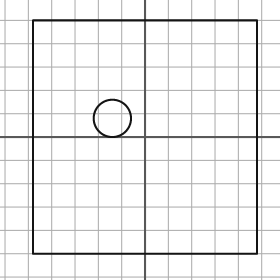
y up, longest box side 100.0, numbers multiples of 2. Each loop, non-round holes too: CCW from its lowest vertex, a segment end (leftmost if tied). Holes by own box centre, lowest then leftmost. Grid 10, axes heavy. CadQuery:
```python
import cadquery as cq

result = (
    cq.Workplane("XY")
    .moveTo(-48.0, -50.0)
    .lineTo(48.0, -50.0)
    .lineTo(48.0, 50.0)
    .lineTo(-48.0, 50.0)
    .close()
    .moveTo(-14.0, 8.0)
    .circle(8.0)
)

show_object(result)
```